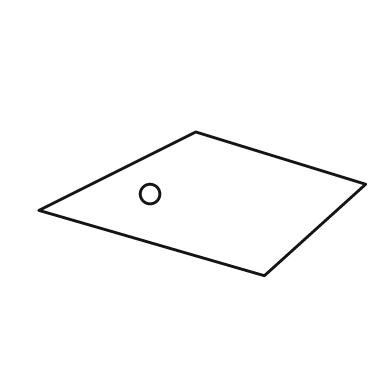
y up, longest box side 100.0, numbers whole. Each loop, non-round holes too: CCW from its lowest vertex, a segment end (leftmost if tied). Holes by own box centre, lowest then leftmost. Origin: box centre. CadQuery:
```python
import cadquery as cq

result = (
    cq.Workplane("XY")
    .moveTo(19.0, -22.0)
    .lineTo(50.0, 6.0)
    .lineTo(-2.0, 22.0)
    .lineTo(-50.0, -2.0)
    .close()
    .moveTo(-16.0, 3.0)
    .circle(3.0)
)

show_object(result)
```